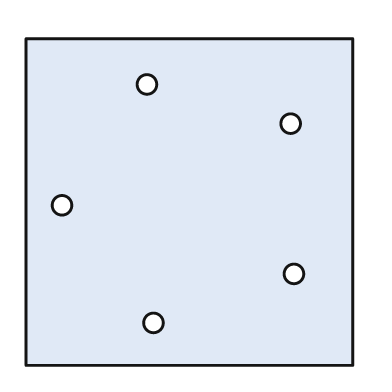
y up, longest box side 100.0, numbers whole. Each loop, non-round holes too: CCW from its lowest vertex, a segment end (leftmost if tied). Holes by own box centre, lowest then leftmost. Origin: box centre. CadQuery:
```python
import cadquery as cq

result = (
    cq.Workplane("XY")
    .moveTo(-50.0, -50.0)
    .lineTo(50.0, -50.0)
    .lineTo(50.0, 50.0)
    .lineTo(-50.0, 50.0)
    .close()
    .moveTo(-11.0, -37.0)
    .circle(3.0)
    .moveTo(32.0, -22.0)
    .circle(3.0)
    .moveTo(-39.0, -1.0)
    .circle(3.0)
    .moveTo(31.0, 24.0)
    .circle(3.0)
    .moveTo(-13.0, 36.0)
    .circle(3.0)
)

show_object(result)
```